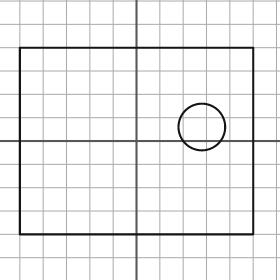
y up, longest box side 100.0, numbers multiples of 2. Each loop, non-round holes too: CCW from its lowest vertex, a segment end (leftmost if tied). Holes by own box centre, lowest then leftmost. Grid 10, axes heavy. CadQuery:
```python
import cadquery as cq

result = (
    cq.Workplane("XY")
    .moveTo(-50.0, -40.0)
    .lineTo(50.0, -40.0)
    .lineTo(50.0, 40.0)
    .lineTo(-50.0, 40.0)
    .close()
    .moveTo(28.0, 6.0)
    .circle(10.0)
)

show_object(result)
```